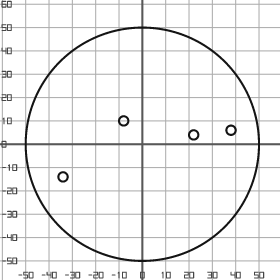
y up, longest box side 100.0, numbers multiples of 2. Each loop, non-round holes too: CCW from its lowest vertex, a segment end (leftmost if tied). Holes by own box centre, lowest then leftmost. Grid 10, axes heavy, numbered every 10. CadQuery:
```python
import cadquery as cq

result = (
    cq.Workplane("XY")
    .moveTo(0.0, 0.0)
    .circle(50.0)
    .moveTo(-34.0, -14.0)
    .circle(2.0)
    .moveTo(22.0, 4.0)
    .circle(2.0)
    .moveTo(38.0, 6.0)
    .circle(2.0)
    .moveTo(-8.0, 10.0)
    .circle(2.0)
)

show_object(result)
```